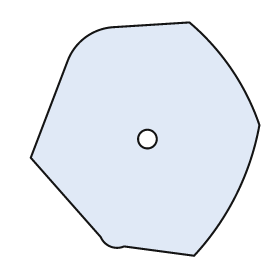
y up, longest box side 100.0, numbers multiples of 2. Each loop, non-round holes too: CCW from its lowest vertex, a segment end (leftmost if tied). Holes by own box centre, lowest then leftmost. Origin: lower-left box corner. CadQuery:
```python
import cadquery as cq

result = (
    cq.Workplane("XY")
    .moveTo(70.0, 0.0)
    .threePointArc((88.0, 26.0), (98.0, 56.0))
    .threePointArc((86.0, 80.0), (68.0, 100.0))
    .lineTo(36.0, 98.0)
    .threePointArc((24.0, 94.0), (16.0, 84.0))
    .lineTo(0.0, 42.0)
    .lineTo(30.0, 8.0)
    .threePointArc((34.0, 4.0), (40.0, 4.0))
    .close()
    .moveTo(50.0, 50.0)
    .circle(4.0)
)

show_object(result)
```